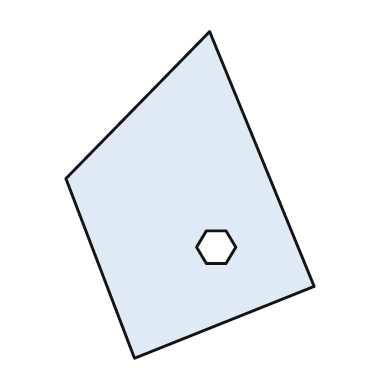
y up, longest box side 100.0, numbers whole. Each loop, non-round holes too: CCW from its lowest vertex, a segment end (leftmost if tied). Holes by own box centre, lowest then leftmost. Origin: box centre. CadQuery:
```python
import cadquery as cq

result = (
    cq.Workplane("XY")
    .moveTo(-17.0, -50.0)
    .lineTo(38.0, -28.0)
    .lineTo(6.0, 50.0)
    .lineTo(-38.0, 5.0)
    .close()
    .moveTo(5.0, -21.0)
    .lineTo(11.0, -21.0)
    .lineTo(14.0, -16.0)
    .lineTo(11.0, -11.0)
    .lineTo(5.0, -11.0)
    .lineTo(2.0, -16.0)
    .close()
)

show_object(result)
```